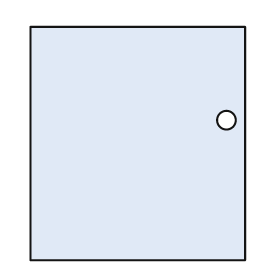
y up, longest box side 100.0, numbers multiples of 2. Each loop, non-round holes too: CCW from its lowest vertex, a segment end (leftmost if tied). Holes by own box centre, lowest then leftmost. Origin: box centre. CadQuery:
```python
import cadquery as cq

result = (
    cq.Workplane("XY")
    .moveTo(-46.0, -50.0)
    .lineTo(46.0, -50.0)
    .lineTo(46.0, 50.0)
    .lineTo(-46.0, 50.0)
    .close()
    .moveTo(38.0, 10.0)
    .circle(4.0)
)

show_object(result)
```